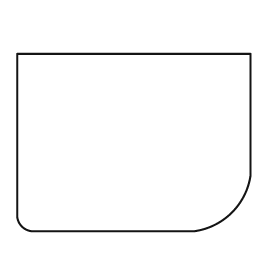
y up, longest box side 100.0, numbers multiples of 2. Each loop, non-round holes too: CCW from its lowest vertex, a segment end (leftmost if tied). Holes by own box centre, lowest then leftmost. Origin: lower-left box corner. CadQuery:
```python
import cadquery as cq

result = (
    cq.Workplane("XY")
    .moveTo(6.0, 0.0)
    .lineTo(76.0, 0.0)
    .threePointArc((92.0, 8.0), (100.0, 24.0))
    .lineTo(100.0, 76.0)
    .lineTo(0.0, 76.0)
    .lineTo(0.0, 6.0)
    .threePointArc((2.0, 2.0), (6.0, 0.0))
    .close()
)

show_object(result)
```